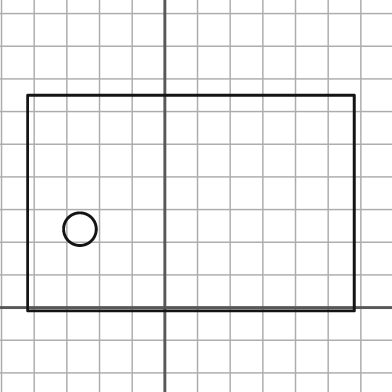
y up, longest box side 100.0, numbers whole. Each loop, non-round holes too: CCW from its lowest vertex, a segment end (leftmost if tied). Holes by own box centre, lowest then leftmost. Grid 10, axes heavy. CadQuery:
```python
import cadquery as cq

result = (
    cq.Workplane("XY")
    .moveTo(-42.0, -1.0)
    .lineTo(58.0, -1.0)
    .lineTo(58.0, 65.0)
    .lineTo(-42.0, 65.0)
    .close()
    .moveTo(-26.0, 24.0)
    .circle(5.0)
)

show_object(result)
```